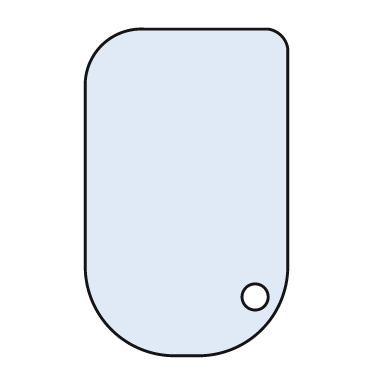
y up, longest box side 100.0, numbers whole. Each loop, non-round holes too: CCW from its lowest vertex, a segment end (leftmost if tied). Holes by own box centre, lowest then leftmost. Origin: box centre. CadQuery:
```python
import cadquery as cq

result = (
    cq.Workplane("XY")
    .moveTo(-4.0, -50.0)
    .lineTo(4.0, -50.0)
    .threePointArc((23.0, -42.0), (31.0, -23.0))
    .lineTo(31.0, 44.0)
    .threePointArc((29.0, 48.0), (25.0, 50.0))
    .lineTo(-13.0, 50.0)
    .threePointArc((-26.0, 45.0), (-31.0, 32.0))
    .lineTo(-31.0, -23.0)
    .threePointArc((-23.0, -42.0), (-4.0, -50.0))
    .close()
    .moveTo(21.0, -32.0)
    .circle(4.0)
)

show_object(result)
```